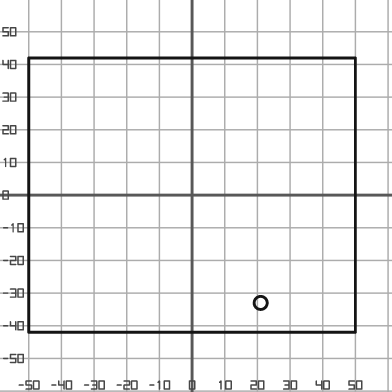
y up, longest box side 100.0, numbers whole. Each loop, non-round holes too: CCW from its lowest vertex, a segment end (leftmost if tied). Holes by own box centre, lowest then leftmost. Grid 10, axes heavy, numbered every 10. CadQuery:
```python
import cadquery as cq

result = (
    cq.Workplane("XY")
    .moveTo(-50.0, -42.0)
    .lineTo(50.0, -42.0)
    .lineTo(50.0, 42.0)
    .lineTo(-50.0, 42.0)
    .close()
    .moveTo(21.0, -33.0)
    .circle(2.0)
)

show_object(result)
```